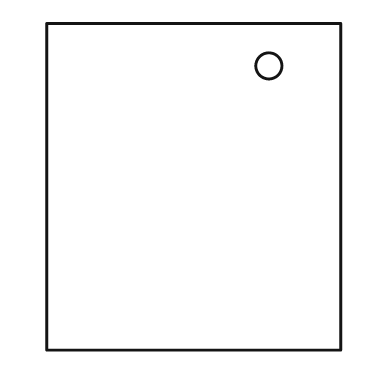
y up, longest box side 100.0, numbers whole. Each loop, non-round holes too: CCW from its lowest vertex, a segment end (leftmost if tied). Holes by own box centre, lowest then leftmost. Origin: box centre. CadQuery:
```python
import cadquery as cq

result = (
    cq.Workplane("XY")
    .moveTo(-45.0, -50.0)
    .lineTo(45.0, -50.0)
    .lineTo(45.0, 50.0)
    .lineTo(-45.0, 50.0)
    .close()
    .moveTo(23.0, 37.0)
    .circle(4.0)
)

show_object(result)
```